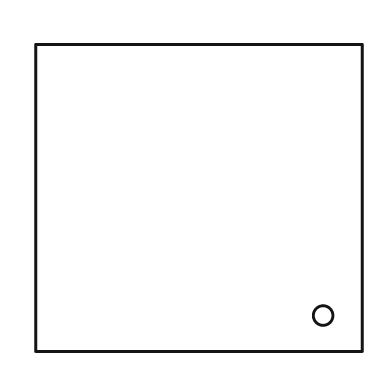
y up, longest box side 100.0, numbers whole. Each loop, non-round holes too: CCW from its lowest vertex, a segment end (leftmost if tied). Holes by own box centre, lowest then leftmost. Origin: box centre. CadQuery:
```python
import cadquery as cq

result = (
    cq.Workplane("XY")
    .moveTo(-50.0, -47.0)
    .lineTo(50.0, -47.0)
    .lineTo(50.0, 47.0)
    .lineTo(-50.0, 47.0)
    .close()
    .moveTo(38.0, -36.0)
    .circle(3.0)
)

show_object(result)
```